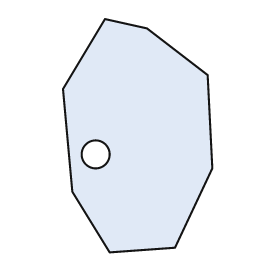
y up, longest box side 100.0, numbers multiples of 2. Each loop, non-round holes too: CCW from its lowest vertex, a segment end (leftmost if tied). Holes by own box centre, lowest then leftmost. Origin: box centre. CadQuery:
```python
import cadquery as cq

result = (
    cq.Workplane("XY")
    .moveTo(-12.0, -50.0)
    .lineTo(16.0, -48.0)
    .lineTo(32.0, -14.0)
    .lineTo(30.0, 26.0)
    .lineTo(4.0, 46.0)
    .lineTo(-14.0, 50.0)
    .lineTo(-32.0, 20.0)
    .lineTo(-28.0, -24.0)
    .close()
    .moveTo(-18.0, -8.0)
    .circle(6.0)
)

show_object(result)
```